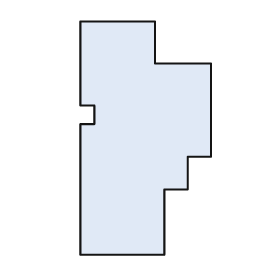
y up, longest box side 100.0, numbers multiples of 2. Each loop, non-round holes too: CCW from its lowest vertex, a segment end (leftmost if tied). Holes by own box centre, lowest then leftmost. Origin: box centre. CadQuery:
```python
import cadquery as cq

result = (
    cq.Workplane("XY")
    .moveTo(-28.0, -50.0)
    .lineTo(8.0, -50.0)
    .lineTo(8.0, -22.0)
    .lineTo(18.0, -22.0)
    .lineTo(18.0, -8.0)
    .lineTo(28.0, -8.0)
    .lineTo(28.0, 32.0)
    .lineTo(4.0, 32.0)
    .lineTo(4.0, 50.0)
    .lineTo(-28.0, 50.0)
    .lineTo(-28.0, 14.0)
    .lineTo(-22.0, 14.0)
    .lineTo(-22.0, 6.0)
    .lineTo(-28.0, 6.0)
    .close()
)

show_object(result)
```